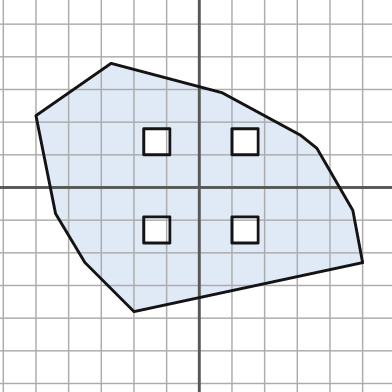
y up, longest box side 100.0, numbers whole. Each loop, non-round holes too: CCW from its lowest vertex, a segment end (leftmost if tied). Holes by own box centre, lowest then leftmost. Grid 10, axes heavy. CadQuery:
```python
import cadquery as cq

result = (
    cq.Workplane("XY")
    .moveTo(-20.0, -38.0)
    .lineTo(50.0, -23.0)
    .lineTo(47.0, -7.0)
    .lineTo(36.0, 12.0)
    .lineTo(31.0, 16.0)
    .lineTo(7.0, 29.0)
    .lineTo(-27.0, 38.0)
    .lineTo(-50.0, 22.0)
    .lineTo(-44.0, -8.0)
    .lineTo(-35.0, -23.0)
    .close()
    .moveTo(-17.0, -17.0)
    .lineTo(-9.0, -17.0)
    .lineTo(-9.0, -9.0)
    .lineTo(-17.0, -9.0)
    .close()
    .moveTo(10.0, -17.0)
    .lineTo(18.0, -17.0)
    .lineTo(18.0, -9.0)
    .lineTo(10.0, -9.0)
    .close()
    .moveTo(-17.0, 10.0)
    .lineTo(-9.0, 10.0)
    .lineTo(-9.0, 18.0)
    .lineTo(-17.0, 18.0)
    .close()
    .moveTo(10.0, 10.0)
    .lineTo(18.0, 10.0)
    .lineTo(18.0, 18.0)
    .lineTo(10.0, 18.0)
    .close()
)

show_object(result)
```